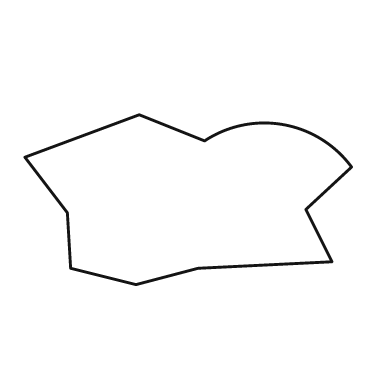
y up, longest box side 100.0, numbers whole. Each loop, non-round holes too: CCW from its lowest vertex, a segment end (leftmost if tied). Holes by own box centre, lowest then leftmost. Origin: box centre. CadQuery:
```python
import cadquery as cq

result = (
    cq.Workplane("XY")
    .moveTo(-16.0, -26.0)
    .lineTo(3.0, -21.0)
    .lineTo(44.0, -19.0)
    .lineTo(36.0, -3.0)
    .lineTo(50.0, 10.0)
    .threePointArc((29.0, 23.0), (5.0, 18.0))
    .lineTo(-15.0, 26.0)
    .lineTo(-50.0, 13.0)
    .lineTo(-37.0, -4.0)
    .lineTo(-36.0, -21.0)
    .close()
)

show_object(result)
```